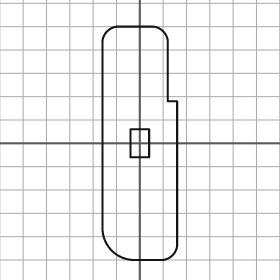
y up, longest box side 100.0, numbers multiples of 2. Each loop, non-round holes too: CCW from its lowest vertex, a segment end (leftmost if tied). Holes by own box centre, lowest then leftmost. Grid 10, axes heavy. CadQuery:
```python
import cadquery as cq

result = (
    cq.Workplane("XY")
    .moveTo(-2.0, -50.0)
    .lineTo(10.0, -50.0)
    .threePointArc((14.0, -48.0), (16.0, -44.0))
    .lineTo(16.0, 18.0)
    .lineTo(12.0, 18.0)
    .lineTo(12.0, 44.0)
    .threePointArc((10.0, 48.0), (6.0, 50.0))
    .lineTo(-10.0, 50.0)
    .threePointArc((-14.0, 48.0), (-16.0, 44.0))
    .lineTo(-16.0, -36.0)
    .threePointArc((-12.0, -46.0), (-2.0, -50.0))
    .close()
    .moveTo(-4.0, -6.0)
    .lineTo(4.0, -6.0)
    .lineTo(4.0, 6.0)
    .lineTo(-4.0, 6.0)
    .close()
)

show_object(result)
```